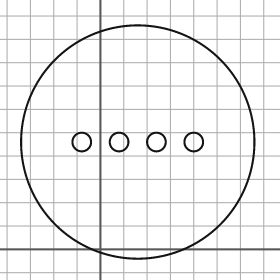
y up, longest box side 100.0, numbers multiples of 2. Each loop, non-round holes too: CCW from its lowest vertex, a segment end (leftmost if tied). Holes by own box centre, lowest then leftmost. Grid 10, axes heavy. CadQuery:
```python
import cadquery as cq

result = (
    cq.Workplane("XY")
    .moveTo(16.0, 46.0)
    .circle(50.0)
    .moveTo(-8.0, 46.0)
    .circle(4.0)
    .moveTo(8.0, 46.0)
    .circle(4.0)
    .moveTo(24.0, 46.0)
    .circle(4.0)
    .moveTo(40.0, 46.0)
    .circle(4.0)
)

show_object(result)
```